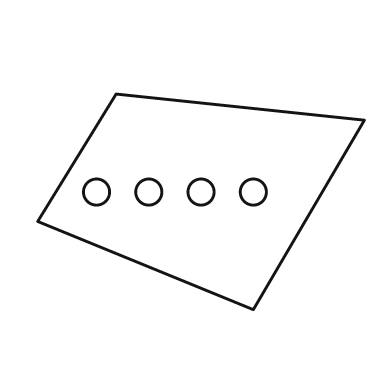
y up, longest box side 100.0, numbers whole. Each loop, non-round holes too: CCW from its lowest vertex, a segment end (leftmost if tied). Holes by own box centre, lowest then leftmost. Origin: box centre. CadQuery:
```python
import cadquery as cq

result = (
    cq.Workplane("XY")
    .moveTo(16.0, -33.0)
    .lineTo(50.0, 25.0)
    .lineTo(-26.0, 33.0)
    .lineTo(-50.0, -6.0)
    .close()
    .moveTo(-32.0, 3.0)
    .circle(4.0)
    .moveTo(-16.0, 3.0)
    .circle(4.0)
    .moveTo(0.0, 3.0)
    .circle(4.0)
    .moveTo(16.0, 3.0)
    .circle(4.0)
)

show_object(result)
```